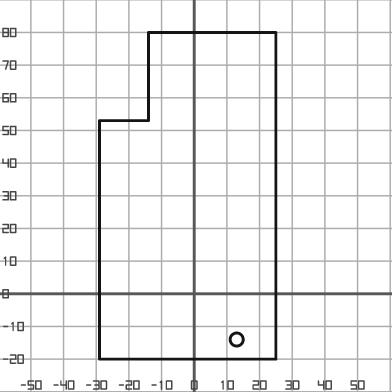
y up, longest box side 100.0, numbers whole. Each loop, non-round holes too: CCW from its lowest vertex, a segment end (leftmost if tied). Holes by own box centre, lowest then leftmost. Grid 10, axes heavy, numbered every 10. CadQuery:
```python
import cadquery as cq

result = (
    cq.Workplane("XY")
    .moveTo(-29.0, -20.0)
    .lineTo(25.0, -20.0)
    .lineTo(25.0, 80.0)
    .lineTo(-14.0, 80.0)
    .lineTo(-14.0, 53.0)
    .lineTo(-29.0, 53.0)
    .close()
    .moveTo(13.0, -14.0)
    .circle(2.0)
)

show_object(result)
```